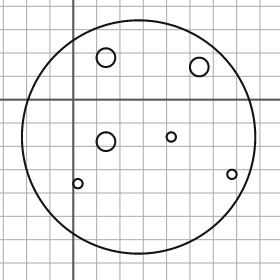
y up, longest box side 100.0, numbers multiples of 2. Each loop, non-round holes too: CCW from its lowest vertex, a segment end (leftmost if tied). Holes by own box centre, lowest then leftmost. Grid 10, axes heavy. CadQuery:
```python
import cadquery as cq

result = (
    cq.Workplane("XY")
    .moveTo(28.0, -16.0)
    .circle(50.0)
    .moveTo(2.0, -36.0)
    .circle(2.0)
    .moveTo(68.0, -32.0)
    .circle(2.0)
    .moveTo(14.0, -18.0)
    .circle(4.0)
    .moveTo(42.0, -16.0)
    .circle(2.0)
    .moveTo(54.0, 14.0)
    .circle(4.0)
    .moveTo(14.0, 18.0)
    .circle(4.0)
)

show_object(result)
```